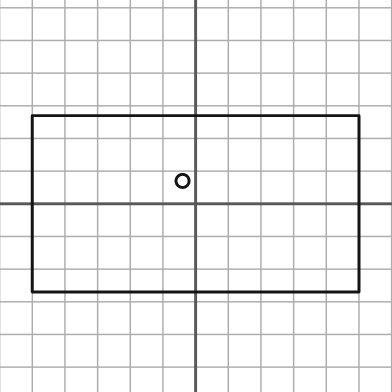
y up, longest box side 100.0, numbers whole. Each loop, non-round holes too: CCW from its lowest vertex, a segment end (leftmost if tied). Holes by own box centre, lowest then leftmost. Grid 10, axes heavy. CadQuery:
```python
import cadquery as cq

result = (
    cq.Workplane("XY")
    .moveTo(-50.0, -27.0)
    .lineTo(50.0, -27.0)
    .lineTo(50.0, 27.0)
    .lineTo(-50.0, 27.0)
    .close()
    .moveTo(-4.0, 7.0)
    .circle(2.0)
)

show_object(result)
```